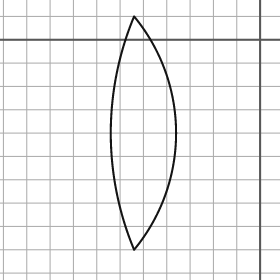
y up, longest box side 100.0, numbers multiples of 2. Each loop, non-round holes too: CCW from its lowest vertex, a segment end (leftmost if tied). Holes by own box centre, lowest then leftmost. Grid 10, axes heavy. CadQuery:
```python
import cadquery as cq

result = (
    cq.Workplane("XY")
    .moveTo(-54.0, -90.0)
    .threePointArc((-36.0, -40.0), (-54.0, 10.0))
    .threePointArc((-64.0, -40.0), (-54.0, -90.0))
    .close()
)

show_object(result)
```